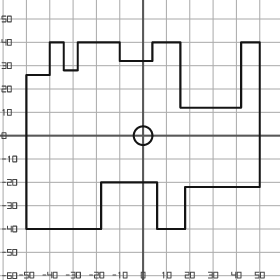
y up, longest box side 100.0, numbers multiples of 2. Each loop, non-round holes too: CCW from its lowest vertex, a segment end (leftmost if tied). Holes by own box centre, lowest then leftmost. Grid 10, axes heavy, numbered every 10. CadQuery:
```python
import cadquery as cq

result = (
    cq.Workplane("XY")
    .moveTo(-50.0, -40.0)
    .lineTo(-18.0, -40.0)
    .lineTo(-18.0, -20.0)
    .lineTo(6.0, -20.0)
    .lineTo(6.0, -40.0)
    .lineTo(18.0, -40.0)
    .lineTo(18.0, -22.0)
    .lineTo(50.0, -22.0)
    .lineTo(50.0, 40.0)
    .lineTo(42.0, 40.0)
    .lineTo(42.0, 12.0)
    .lineTo(16.0, 12.0)
    .lineTo(16.0, 40.0)
    .lineTo(4.0, 40.0)
    .lineTo(4.0, 32.0)
    .lineTo(-10.0, 32.0)
    .lineTo(-10.0, 40.0)
    .lineTo(-28.0, 40.0)
    .lineTo(-28.0, 28.0)
    .lineTo(-34.0, 28.0)
    .lineTo(-34.0, 40.0)
    .lineTo(-40.0, 40.0)
    .lineTo(-40.0, 26.0)
    .lineTo(-50.0, 26.0)
    .close()
    .moveTo(0.0, 0.0)
    .circle(4.0)
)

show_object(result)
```